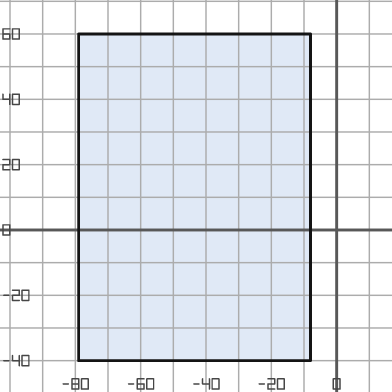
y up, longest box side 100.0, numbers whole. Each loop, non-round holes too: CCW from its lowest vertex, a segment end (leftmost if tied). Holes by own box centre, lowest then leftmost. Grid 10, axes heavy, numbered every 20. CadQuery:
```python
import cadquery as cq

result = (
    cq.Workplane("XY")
    .moveTo(-79.0, -40.0)
    .lineTo(-8.0, -40.0)
    .lineTo(-8.0, 60.0)
    .lineTo(-79.0, 60.0)
    .close()
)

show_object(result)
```